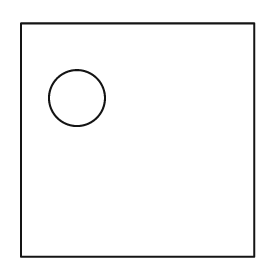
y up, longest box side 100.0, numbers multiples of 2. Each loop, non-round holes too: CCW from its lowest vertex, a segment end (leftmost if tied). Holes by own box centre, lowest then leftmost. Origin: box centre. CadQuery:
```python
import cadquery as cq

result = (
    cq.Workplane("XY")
    .moveTo(-50.0, -50.0)
    .lineTo(50.0, -50.0)
    .lineTo(50.0, 50.0)
    .lineTo(-50.0, 50.0)
    .close()
    .moveTo(-26.0, 18.0)
    .circle(12.0)
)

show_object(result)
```